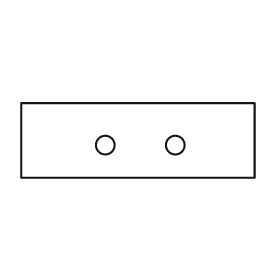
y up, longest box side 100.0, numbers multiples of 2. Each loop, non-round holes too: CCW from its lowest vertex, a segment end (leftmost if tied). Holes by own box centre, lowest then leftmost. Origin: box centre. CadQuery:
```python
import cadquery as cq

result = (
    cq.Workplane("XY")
    .moveTo(-50.0, -16.0)
    .lineTo(50.0, -16.0)
    .lineTo(50.0, 16.0)
    .lineTo(-50.0, 16.0)
    .close()
    .moveTo(-14.0, -2.0)
    .circle(4.0)
    .moveTo(16.0, -2.0)
    .circle(4.0)
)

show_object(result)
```